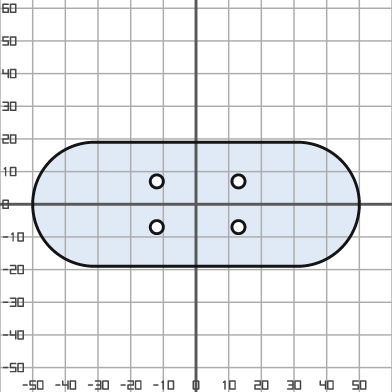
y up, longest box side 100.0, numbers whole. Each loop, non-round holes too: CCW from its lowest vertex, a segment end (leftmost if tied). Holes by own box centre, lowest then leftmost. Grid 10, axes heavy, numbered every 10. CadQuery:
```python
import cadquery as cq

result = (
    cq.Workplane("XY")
    .moveTo(-31.0, -19.0)
    .lineTo(31.0, -19.0)
    .threePointArc((50.0, 0.0), (31.0, 19.0))
    .lineTo(-31.0, 19.0)
    .threePointArc((-50.0, 0.0), (-31.0, -19.0))
    .close()
    .moveTo(-12.0, -7.0)
    .circle(2.0)
    .moveTo(13.0, -7.0)
    .circle(2.0)
    .moveTo(-12.0, 7.0)
    .circle(2.0)
    .moveTo(13.0, 7.0)
    .circle(2.0)
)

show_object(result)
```